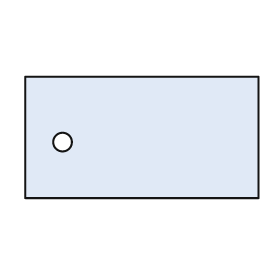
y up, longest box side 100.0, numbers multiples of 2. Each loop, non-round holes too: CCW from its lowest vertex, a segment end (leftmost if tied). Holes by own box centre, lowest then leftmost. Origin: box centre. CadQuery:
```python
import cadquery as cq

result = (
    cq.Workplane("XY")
    .moveTo(-50.0, -26.0)
    .lineTo(50.0, -26.0)
    .lineTo(50.0, 26.0)
    .lineTo(-50.0, 26.0)
    .close()
    .moveTo(-34.0, -2.0)
    .circle(4.0)
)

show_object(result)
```